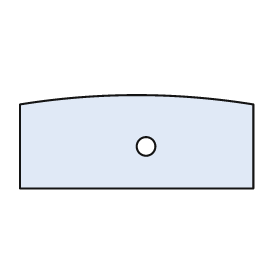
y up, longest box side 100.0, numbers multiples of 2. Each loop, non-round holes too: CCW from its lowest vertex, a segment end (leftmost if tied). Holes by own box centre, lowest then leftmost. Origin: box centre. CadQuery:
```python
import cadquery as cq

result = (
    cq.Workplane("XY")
    .moveTo(-50.0, -20.0)
    .lineTo(50.0, -20.0)
    .lineTo(50.0, 16.0)
    .threePointArc((0.0, 20.0), (-50.0, 16.0))
    .close()
    .moveTo(4.0, -2.0)
    .circle(4.0)
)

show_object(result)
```